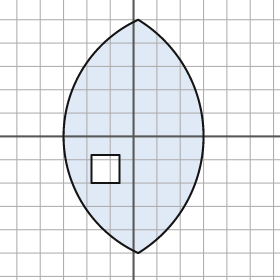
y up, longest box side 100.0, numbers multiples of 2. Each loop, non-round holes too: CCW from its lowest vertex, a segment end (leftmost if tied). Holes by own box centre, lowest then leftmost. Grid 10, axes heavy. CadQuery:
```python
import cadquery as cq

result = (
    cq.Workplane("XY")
    .moveTo(2.0, -50.0)
    .threePointArc((30.0, 0.0), (2.0, 50.0))
    .threePointArc((-30.0, 0.0), (2.0, -50.0))
    .close()
    .moveTo(-18.0, -20.0)
    .lineTo(-6.0, -20.0)
    .lineTo(-6.0, -8.0)
    .lineTo(-18.0, -8.0)
    .close()
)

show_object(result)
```